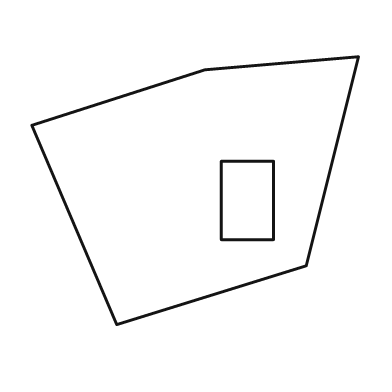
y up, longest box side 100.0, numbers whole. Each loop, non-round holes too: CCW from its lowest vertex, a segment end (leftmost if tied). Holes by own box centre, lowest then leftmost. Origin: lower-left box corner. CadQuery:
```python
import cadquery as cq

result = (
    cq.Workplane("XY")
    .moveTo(26.0, 0.0)
    .lineTo(84.0, 18.0)
    .lineTo(100.0, 82.0)
    .lineTo(53.0, 78.0)
    .lineTo(0.0, 61.0)
    .close()
    .moveTo(58.0, 26.0)
    .lineTo(74.0, 26.0)
    .lineTo(74.0, 50.0)
    .lineTo(58.0, 50.0)
    .close()
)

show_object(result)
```